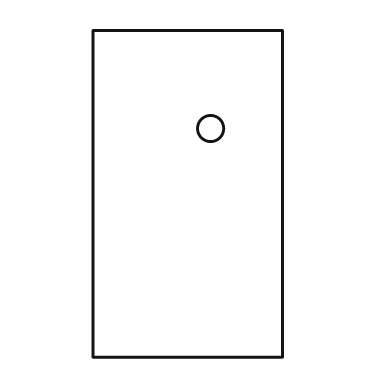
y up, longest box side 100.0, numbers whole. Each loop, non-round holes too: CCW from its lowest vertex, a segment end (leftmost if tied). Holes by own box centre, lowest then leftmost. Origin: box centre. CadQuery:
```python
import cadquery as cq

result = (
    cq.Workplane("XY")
    .moveTo(-29.0, -50.0)
    .lineTo(29.0, -50.0)
    .lineTo(29.0, 50.0)
    .lineTo(-29.0, 50.0)
    .close()
    .moveTo(7.0, 20.0)
    .circle(4.0)
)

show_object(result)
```